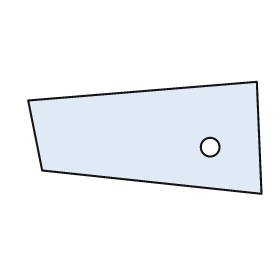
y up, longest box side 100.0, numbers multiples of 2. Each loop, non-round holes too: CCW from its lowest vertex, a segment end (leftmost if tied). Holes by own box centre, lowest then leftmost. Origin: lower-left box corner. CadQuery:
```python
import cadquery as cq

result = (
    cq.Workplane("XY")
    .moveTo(100.0, 0.0)
    .lineTo(98.0, 48.0)
    .lineTo(0.0, 40.0)
    .lineTo(6.0, 10.0)
    .close()
    .moveTo(78.0, 20.0)
    .circle(4.0)
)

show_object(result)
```